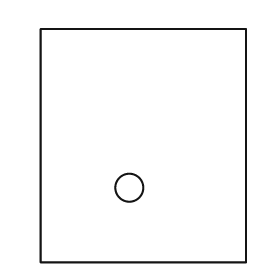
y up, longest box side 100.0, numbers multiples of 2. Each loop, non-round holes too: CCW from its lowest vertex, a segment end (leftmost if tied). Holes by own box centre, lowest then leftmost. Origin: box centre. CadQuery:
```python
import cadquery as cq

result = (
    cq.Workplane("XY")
    .moveTo(-44.0, -50.0)
    .lineTo(44.0, -50.0)
    .lineTo(44.0, 50.0)
    .lineTo(-44.0, 50.0)
    .close()
    .moveTo(-6.0, -18.0)
    .circle(6.0)
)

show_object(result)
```